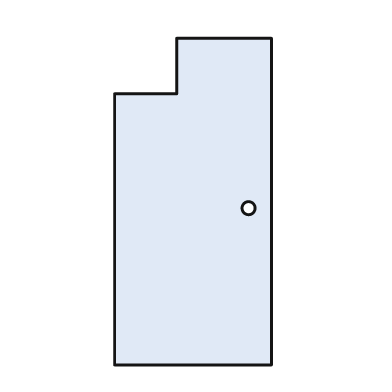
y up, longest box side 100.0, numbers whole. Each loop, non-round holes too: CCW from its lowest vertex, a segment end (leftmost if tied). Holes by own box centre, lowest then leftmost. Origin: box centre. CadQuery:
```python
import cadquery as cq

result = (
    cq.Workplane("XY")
    .moveTo(-24.0, -50.0)
    .lineTo(24.0, -50.0)
    .lineTo(24.0, 50.0)
    .lineTo(-5.0, 50.0)
    .lineTo(-5.0, 33.0)
    .lineTo(-24.0, 33.0)
    .close()
    .moveTo(17.0, -2.0)
    .circle(2.0)
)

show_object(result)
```